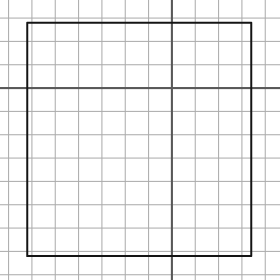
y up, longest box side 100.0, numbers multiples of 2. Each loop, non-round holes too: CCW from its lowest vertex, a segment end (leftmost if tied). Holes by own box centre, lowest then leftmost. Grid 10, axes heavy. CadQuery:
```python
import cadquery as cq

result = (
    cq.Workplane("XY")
    .moveTo(-62.0, -72.0)
    .lineTo(34.0, -72.0)
    .lineTo(34.0, 28.0)
    .lineTo(-62.0, 28.0)
    .close()
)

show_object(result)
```